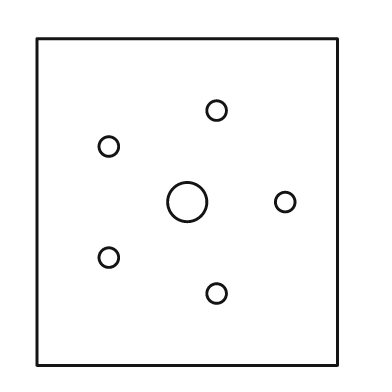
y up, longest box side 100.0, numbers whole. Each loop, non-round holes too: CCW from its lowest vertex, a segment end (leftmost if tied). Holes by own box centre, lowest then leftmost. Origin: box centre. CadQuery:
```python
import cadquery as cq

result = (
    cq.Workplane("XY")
    .moveTo(-46.0, -50.0)
    .lineTo(46.0, -50.0)
    .lineTo(46.0, 50.0)
    .lineTo(-46.0, 50.0)
    .close()
    .moveTo(9.0, -28.0)
    .circle(3.0)
    .moveTo(-24.0, -17.0)
    .circle(3.0)
    .moveTo(0.0, 0.0)
    .circle(6.0)
    .moveTo(30.0, 0.0)
    .circle(3.0)
    .moveTo(-24.0, 17.0)
    .circle(3.0)
    .moveTo(9.0, 28.0)
    .circle(3.0)
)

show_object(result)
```